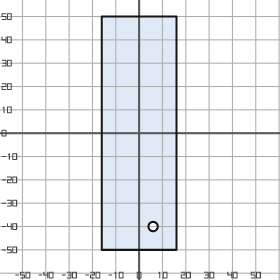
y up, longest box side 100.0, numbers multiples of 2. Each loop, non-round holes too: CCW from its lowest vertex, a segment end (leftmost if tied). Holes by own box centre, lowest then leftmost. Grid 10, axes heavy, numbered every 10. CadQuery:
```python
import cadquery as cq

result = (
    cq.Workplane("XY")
    .moveTo(-16.0, -50.0)
    .lineTo(16.0, -50.0)
    .lineTo(16.0, 50.0)
    .lineTo(-16.0, 50.0)
    .close()
    .moveTo(6.0, -40.0)
    .circle(2.0)
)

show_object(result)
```